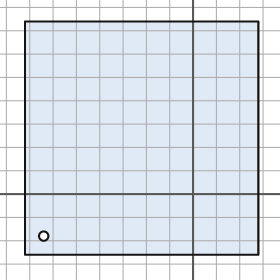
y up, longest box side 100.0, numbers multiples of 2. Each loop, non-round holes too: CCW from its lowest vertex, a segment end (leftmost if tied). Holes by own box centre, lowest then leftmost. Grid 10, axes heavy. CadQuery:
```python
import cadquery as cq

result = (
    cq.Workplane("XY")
    .moveTo(-72.0, -26.0)
    .lineTo(28.0, -26.0)
    .lineTo(28.0, 74.0)
    .lineTo(-72.0, 74.0)
    .close()
    .moveTo(-64.0, -18.0)
    .circle(2.0)
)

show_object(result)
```